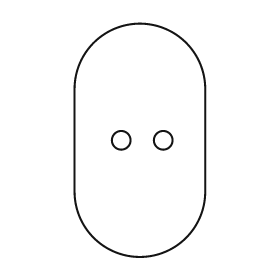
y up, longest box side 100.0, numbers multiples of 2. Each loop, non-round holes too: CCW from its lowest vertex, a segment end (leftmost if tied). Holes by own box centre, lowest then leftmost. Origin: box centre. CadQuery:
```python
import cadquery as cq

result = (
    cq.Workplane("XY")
    .moveTo(-28.0, -22.0)
    .threePointArc((0.0, -50.0), (28.0, -22.0))
    .lineTo(28.0, 22.0)
    .threePointArc((0.0, 50.0), (-28.0, 22.0))
    .close()
    .moveTo(-8.0, 0.0)
    .circle(4.0)
    .moveTo(10.0, 0.0)
    .circle(4.0)
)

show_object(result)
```